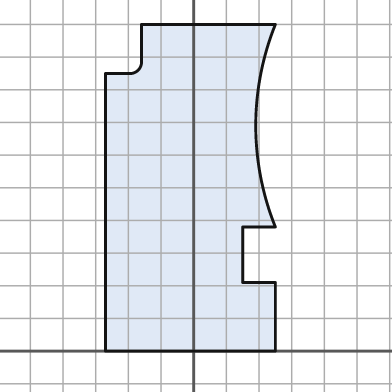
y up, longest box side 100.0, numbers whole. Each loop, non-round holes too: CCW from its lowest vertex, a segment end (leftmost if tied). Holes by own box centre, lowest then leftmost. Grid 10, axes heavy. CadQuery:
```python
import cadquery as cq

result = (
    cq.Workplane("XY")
    .moveTo(-27.0, 0.0)
    .lineTo(25.0, 0.0)
    .lineTo(25.0, 21.0)
    .lineTo(15.0, 21.0)
    .lineTo(15.0, 38.0)
    .lineTo(25.0, 38.0)
    .threePointArc((19.0, 69.0), (25.0, 100.0))
    .lineTo(-16.0, 100.0)
    .lineTo(-16.0, 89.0)
    .threePointArc((-17.0, 86.0), (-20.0, 85.0))
    .lineTo(-27.0, 85.0)
    .close()
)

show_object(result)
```